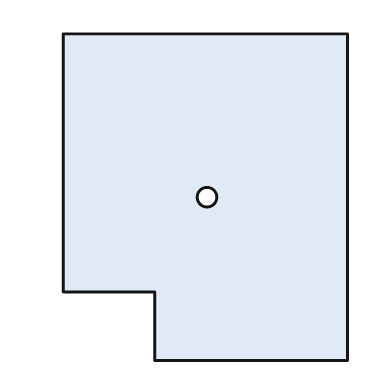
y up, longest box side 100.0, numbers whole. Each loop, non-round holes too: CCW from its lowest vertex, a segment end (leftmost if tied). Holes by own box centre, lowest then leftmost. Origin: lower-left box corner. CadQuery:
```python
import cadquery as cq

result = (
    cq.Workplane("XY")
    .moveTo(28.0, 0.0)
    .lineTo(87.0, 0.0)
    .lineTo(87.0, 100.0)
    .lineTo(0.0, 100.0)
    .lineTo(0.0, 21.0)
    .lineTo(28.0, 21.0)
    .close()
    .moveTo(44.0, 50.0)
    .circle(3.0)
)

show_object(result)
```